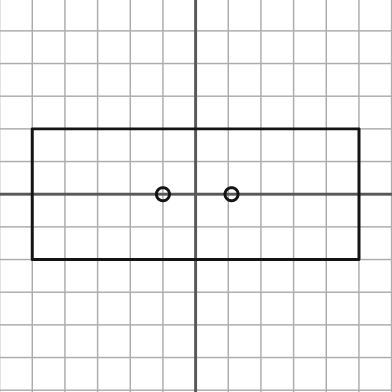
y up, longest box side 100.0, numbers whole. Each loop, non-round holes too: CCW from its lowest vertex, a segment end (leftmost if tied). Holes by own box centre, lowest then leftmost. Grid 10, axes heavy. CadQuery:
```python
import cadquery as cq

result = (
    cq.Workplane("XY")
    .moveTo(-50.0, -20.0)
    .lineTo(50.0, -20.0)
    .lineTo(50.0, 20.0)
    .lineTo(-50.0, 20.0)
    .close()
    .moveTo(-10.0, 0.0)
    .circle(2.0)
    .moveTo(11.0, 0.0)
    .circle(2.0)
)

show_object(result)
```